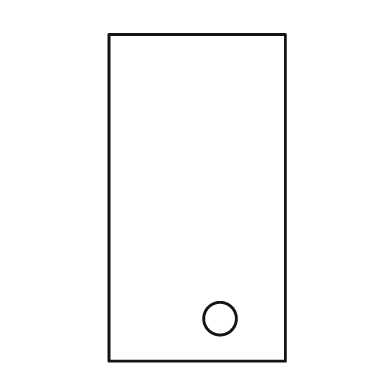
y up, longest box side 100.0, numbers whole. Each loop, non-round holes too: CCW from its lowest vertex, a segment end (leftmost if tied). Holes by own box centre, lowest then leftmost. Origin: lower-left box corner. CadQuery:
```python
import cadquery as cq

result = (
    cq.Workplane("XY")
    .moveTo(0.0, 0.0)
    .lineTo(54.0, 0.0)
    .lineTo(54.0, 100.0)
    .lineTo(0.0, 100.0)
    .close()
    .moveTo(34.0, 13.0)
    .circle(5.0)
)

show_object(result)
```